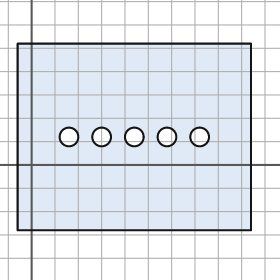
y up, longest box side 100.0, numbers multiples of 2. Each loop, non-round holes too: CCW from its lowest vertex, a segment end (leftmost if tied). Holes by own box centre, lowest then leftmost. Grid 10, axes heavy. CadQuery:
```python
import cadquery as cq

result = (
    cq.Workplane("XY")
    .moveTo(-6.0, -28.0)
    .lineTo(94.0, -28.0)
    .lineTo(94.0, 52.0)
    .lineTo(-6.0, 52.0)
    .close()
    .moveTo(16.0, 12.0)
    .circle(4.0)
    .moveTo(30.0, 12.0)
    .circle(4.0)
    .moveTo(44.0, 12.0)
    .circle(4.0)
    .moveTo(58.0, 12.0)
    .circle(4.0)
    .moveTo(72.0, 12.0)
    .circle(4.0)
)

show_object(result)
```